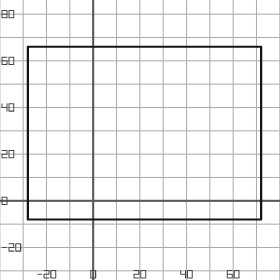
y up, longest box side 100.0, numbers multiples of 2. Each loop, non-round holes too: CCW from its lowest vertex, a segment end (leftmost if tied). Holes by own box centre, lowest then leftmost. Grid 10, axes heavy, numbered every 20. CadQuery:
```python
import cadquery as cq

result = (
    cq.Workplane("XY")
    .moveTo(-28.0, -8.0)
    .lineTo(72.0, -8.0)
    .lineTo(72.0, 66.0)
    .lineTo(-28.0, 66.0)
    .close()
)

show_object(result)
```